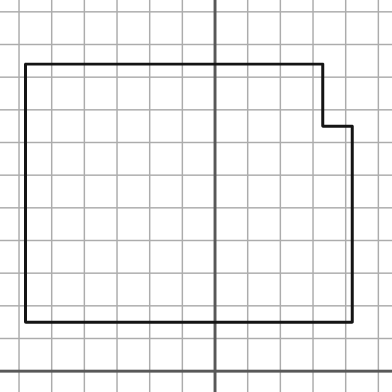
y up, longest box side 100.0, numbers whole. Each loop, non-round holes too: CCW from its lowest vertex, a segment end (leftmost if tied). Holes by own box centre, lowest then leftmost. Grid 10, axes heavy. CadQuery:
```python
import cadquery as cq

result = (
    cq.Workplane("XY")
    .moveTo(-58.0, 15.0)
    .lineTo(42.0, 15.0)
    .lineTo(42.0, 75.0)
    .lineTo(33.0, 75.0)
    .lineTo(33.0, 94.0)
    .lineTo(-58.0, 94.0)
    .close()
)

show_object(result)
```